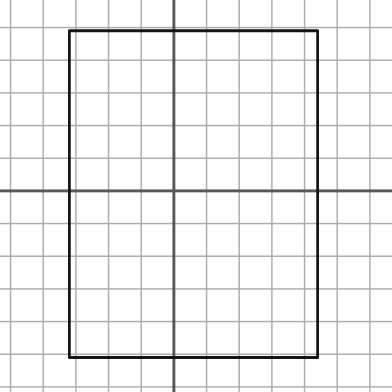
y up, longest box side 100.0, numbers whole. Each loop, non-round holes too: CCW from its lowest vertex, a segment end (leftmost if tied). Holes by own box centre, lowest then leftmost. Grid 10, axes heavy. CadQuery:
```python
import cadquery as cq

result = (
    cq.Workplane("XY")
    .moveTo(-32.0, -51.0)
    .lineTo(44.0, -51.0)
    .lineTo(44.0, 49.0)
    .lineTo(-32.0, 49.0)
    .close()
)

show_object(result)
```